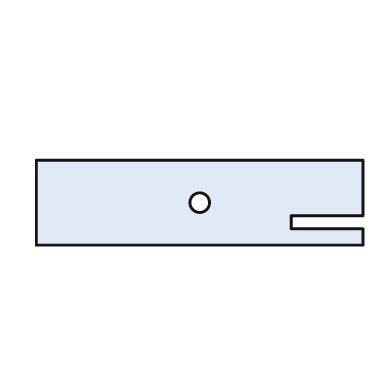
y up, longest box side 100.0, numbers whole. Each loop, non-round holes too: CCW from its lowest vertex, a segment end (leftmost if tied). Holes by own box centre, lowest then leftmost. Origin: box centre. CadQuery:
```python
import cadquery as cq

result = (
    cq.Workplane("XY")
    .moveTo(-50.0, -13.0)
    .lineTo(50.0, -13.0)
    .lineTo(50.0, -8.0)
    .lineTo(28.0, -8.0)
    .lineTo(28.0, -4.0)
    .lineTo(50.0, -4.0)
    .lineTo(50.0, 13.0)
    .lineTo(-50.0, 13.0)
    .close()
    .moveTo(0.0, 0.0)
    .circle(3.0)
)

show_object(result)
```